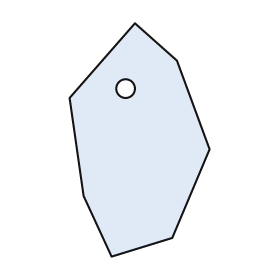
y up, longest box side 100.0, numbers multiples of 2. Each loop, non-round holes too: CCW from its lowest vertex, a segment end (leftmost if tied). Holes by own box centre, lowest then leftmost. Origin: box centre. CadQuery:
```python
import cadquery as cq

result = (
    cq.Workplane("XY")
    .moveTo(-12.0, -50.0)
    .lineTo(14.0, -42.0)
    .lineTo(30.0, -4.0)
    .lineTo(16.0, 34.0)
    .lineTo(-2.0, 50.0)
    .lineTo(-30.0, 18.0)
    .lineTo(-24.0, -24.0)
    .close()
    .moveTo(-6.0, 22.0)
    .circle(4.0)
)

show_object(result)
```